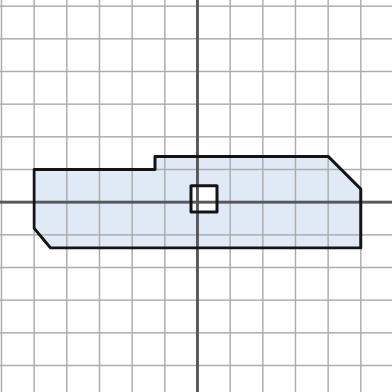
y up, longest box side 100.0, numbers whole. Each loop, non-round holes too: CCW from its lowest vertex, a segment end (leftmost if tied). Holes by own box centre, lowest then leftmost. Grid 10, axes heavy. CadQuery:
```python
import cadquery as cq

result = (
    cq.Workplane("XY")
    .moveTo(-45.0, -14.0)
    .lineTo(50.0, -14.0)
    .lineTo(50.0, 4.0)
    .lineTo(40.0, 14.0)
    .lineTo(-13.0, 14.0)
    .lineTo(-13.0, 10.0)
    .lineTo(-50.0, 10.0)
    .lineTo(-50.0, -8.0)
    .close()
    .moveTo(-2.0, -3.0)
    .lineTo(6.0, -3.0)
    .lineTo(6.0, 5.0)
    .lineTo(-2.0, 5.0)
    .close()
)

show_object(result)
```